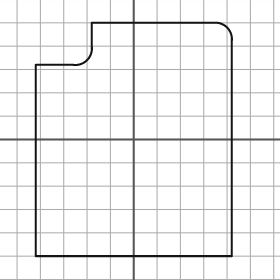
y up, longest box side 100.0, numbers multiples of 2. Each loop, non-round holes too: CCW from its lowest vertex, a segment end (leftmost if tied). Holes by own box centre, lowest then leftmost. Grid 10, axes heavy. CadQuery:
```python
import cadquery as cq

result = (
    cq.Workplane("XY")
    .moveTo(-42.0, -50.0)
    .lineTo(42.0, -50.0)
    .lineTo(42.0, 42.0)
    .threePointArc((40.0, 48.0), (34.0, 50.0))
    .lineTo(-18.0, 50.0)
    .lineTo(-18.0, 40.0)
    .threePointArc((-20.0, 34.0), (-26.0, 32.0))
    .lineTo(-42.0, 32.0)
    .close()
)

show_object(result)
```